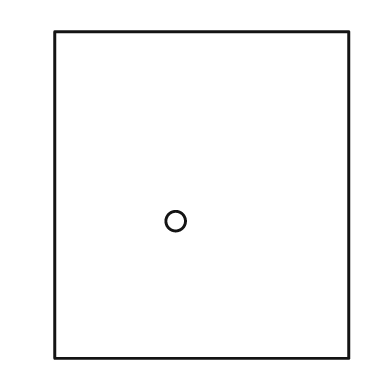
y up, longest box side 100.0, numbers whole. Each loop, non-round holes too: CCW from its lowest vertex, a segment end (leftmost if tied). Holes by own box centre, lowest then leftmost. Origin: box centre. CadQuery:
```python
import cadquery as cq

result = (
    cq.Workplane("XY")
    .moveTo(-45.0, -50.0)
    .lineTo(45.0, -50.0)
    .lineTo(45.0, 50.0)
    .lineTo(-45.0, 50.0)
    .close()
    .moveTo(-8.0, -8.0)
    .circle(3.0)
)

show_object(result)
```